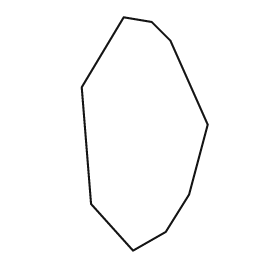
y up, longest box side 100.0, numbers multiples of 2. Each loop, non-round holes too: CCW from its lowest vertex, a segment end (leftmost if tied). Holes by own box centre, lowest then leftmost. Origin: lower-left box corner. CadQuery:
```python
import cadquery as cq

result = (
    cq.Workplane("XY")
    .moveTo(22.0, 0.0)
    .lineTo(36.0, 8.0)
    .lineTo(46.0, 24.0)
    .lineTo(54.0, 54.0)
    .lineTo(38.0, 90.0)
    .lineTo(30.0, 98.0)
    .lineTo(18.0, 100.0)
    .lineTo(0.0, 70.0)
    .lineTo(4.0, 20.0)
    .close()
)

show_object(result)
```